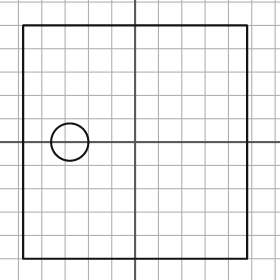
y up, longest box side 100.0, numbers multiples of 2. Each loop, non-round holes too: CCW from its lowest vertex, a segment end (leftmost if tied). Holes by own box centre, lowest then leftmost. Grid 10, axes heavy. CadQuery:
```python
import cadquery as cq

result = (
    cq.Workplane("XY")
    .moveTo(-48.0, -50.0)
    .lineTo(48.0, -50.0)
    .lineTo(48.0, 50.0)
    .lineTo(-48.0, 50.0)
    .close()
    .moveTo(-28.0, 0.0)
    .circle(8.0)
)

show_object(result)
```